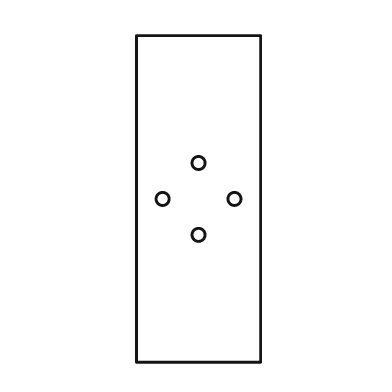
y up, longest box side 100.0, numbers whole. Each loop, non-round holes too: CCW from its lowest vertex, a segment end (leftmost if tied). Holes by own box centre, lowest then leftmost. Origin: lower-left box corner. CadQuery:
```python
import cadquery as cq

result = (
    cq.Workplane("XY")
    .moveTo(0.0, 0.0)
    .lineTo(38.0, 0.0)
    .lineTo(38.0, 100.0)
    .lineTo(0.0, 100.0)
    .close()
    .moveTo(19.0, 39.0)
    .circle(2.0)
    .moveTo(8.0, 50.0)
    .circle(2.0)
    .moveTo(30.0, 50.0)
    .circle(2.0)
    .moveTo(19.0, 61.0)
    .circle(2.0)
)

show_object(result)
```